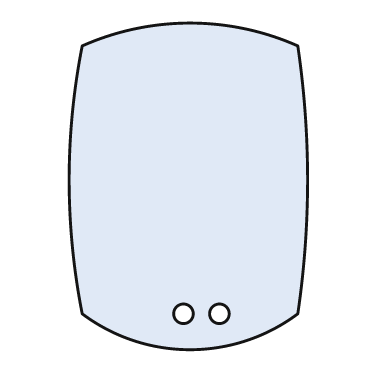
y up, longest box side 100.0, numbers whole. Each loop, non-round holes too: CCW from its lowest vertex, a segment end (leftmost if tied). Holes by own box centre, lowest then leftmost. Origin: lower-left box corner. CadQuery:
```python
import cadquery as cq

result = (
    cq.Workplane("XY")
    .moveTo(4.0, 11.0)
    .threePointArc((37.0, 0.0), (70.0, 11.0))
    .threePointArc((73.0, 52.0), (70.0, 93.0))
    .threePointArc((37.0, 100.0), (4.0, 93.0))
    .threePointArc((0.0, 52.0), (4.0, 11.0))
    .close()
    .moveTo(35.0, 11.0)
    .circle(3.0)
    .moveTo(46.0, 11.0)
    .circle(3.0)
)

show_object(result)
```